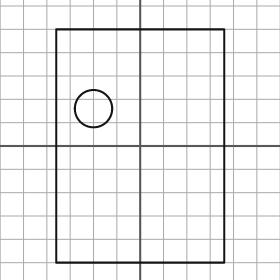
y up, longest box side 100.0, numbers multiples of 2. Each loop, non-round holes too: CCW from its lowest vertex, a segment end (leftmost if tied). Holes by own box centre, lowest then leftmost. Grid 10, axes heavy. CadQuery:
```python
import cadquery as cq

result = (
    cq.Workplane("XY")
    .moveTo(-36.0, -50.0)
    .lineTo(36.0, -50.0)
    .lineTo(36.0, 50.0)
    .lineTo(-36.0, 50.0)
    .close()
    .moveTo(-20.0, 16.0)
    .circle(8.0)
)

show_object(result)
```